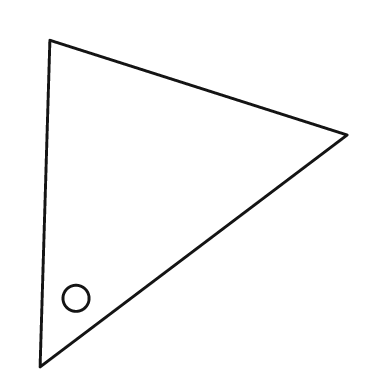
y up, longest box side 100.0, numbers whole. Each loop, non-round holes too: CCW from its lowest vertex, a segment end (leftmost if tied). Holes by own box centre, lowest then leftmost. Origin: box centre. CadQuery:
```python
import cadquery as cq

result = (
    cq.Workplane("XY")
    .moveTo(-47.0, -50.0)
    .lineTo(47.0, 21.0)
    .lineTo(-44.0, 50.0)
    .close()
    .moveTo(-36.0, -29.0)
    .circle(4.0)
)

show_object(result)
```